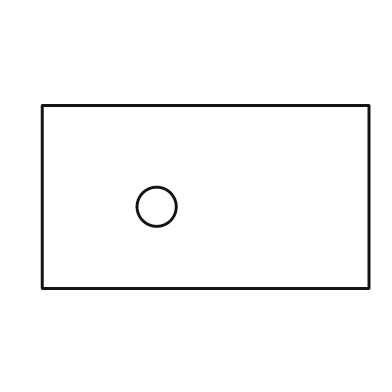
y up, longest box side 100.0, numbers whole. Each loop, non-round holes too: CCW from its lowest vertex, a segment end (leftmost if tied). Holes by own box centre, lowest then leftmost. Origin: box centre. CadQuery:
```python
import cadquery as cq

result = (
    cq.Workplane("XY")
    .moveTo(-50.0, -28.0)
    .lineTo(50.0, -28.0)
    .lineTo(50.0, 28.0)
    .lineTo(-50.0, 28.0)
    .close()
    .moveTo(-15.0, -3.0)
    .circle(6.0)
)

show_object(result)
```